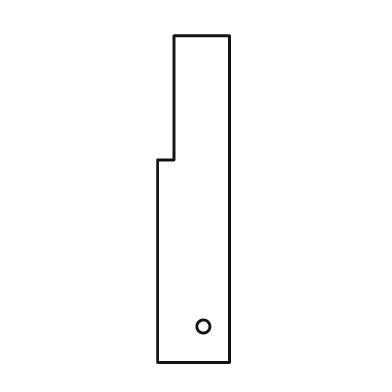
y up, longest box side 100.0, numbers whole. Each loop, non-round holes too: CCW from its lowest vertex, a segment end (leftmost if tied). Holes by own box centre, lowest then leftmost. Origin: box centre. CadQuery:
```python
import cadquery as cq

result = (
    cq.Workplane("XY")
    .moveTo(-11.0, -50.0)
    .lineTo(11.0, -50.0)
    .lineTo(11.0, 50.0)
    .lineTo(-6.0, 50.0)
    .lineTo(-6.0, 12.0)
    .lineTo(-11.0, 12.0)
    .close()
    .moveTo(3.0, -39.0)
    .circle(2.0)
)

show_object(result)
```